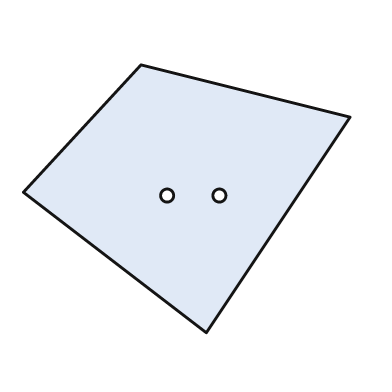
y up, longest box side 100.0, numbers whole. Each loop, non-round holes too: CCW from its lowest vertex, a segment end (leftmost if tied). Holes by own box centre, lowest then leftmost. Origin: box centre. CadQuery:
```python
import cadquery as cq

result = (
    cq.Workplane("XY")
    .moveTo(6.0, -41.0)
    .lineTo(50.0, 25.0)
    .lineTo(-14.0, 41.0)
    .lineTo(-50.0, 2.0)
    .close()
    .moveTo(-6.0, 1.0)
    .circle(2.0)
    .moveTo(10.0, 1.0)
    .circle(2.0)
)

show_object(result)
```